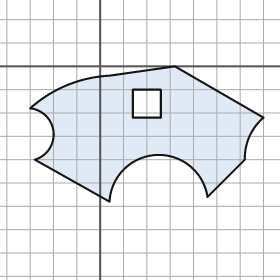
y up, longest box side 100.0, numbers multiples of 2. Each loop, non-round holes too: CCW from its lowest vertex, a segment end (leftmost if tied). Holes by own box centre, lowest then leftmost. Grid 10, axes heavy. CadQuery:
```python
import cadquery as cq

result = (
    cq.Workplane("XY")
    .moveTo(4.0, -58.0)
    .threePointArc((24.0, -38.0), (46.0, -56.0))
    .lineTo(62.0, -40.0)
    .threePointArc((64.0, -30.0), (70.0, -22.0))
    .lineTo(32.0, 0.0)
    .lineTo(4.0, -4.0)
    .threePointArc((-14.0, -8.0), (-30.0, -18.0))
    .threePointArc((-20.0, -28.0), (-28.0, -40.0))
    .close()
    .moveTo(14.0, -22.0)
    .lineTo(26.0, -22.0)
    .lineTo(26.0, -10.0)
    .lineTo(14.0, -10.0)
    .close()
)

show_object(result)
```